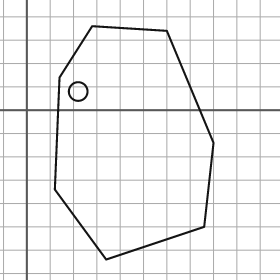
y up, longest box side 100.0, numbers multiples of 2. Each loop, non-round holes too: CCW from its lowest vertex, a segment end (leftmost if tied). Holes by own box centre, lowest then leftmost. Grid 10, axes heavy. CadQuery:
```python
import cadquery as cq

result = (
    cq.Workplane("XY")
    .moveTo(34.0, -64.0)
    .lineTo(76.0, -50.0)
    .lineTo(80.0, -14.0)
    .lineTo(60.0, 34.0)
    .lineTo(28.0, 36.0)
    .lineTo(14.0, 14.0)
    .lineTo(12.0, -34.0)
    .close()
    .moveTo(22.0, 8.0)
    .circle(4.0)
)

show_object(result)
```